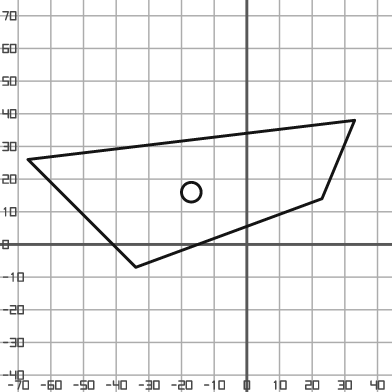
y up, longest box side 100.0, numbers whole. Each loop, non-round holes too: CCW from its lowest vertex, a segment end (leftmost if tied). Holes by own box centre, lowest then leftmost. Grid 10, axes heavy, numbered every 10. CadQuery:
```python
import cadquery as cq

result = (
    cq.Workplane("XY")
    .moveTo(-34.0, -7.0)
    .lineTo(23.0, 14.0)
    .lineTo(33.0, 38.0)
    .lineTo(-67.0, 26.0)
    .close()
    .moveTo(-17.0, 16.0)
    .circle(3.0)
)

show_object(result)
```